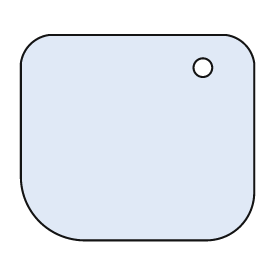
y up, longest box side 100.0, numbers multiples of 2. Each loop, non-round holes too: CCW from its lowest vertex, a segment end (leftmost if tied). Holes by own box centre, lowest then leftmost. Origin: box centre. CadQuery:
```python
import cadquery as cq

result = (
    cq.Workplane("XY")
    .moveTo(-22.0, -44.0)
    .lineTo(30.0, -44.0)
    .threePointArc((44.0, -38.0), (50.0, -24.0))
    .lineTo(50.0, 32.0)
    .threePointArc((46.0, 40.0), (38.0, 44.0))
    .lineTo(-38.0, 44.0)
    .threePointArc((-46.0, 40.0), (-50.0, 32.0))
    .lineTo(-50.0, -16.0)
    .threePointArc((-42.0, -36.0), (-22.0, -44.0))
    .close()
    .moveTo(28.0, 30.0)
    .circle(4.0)
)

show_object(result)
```